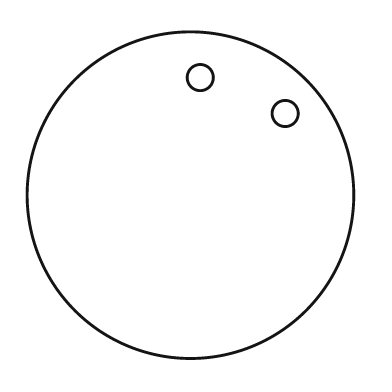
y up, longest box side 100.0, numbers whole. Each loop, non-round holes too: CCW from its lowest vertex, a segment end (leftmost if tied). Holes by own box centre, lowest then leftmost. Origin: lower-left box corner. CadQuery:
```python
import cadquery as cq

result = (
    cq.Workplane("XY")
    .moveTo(50.0, 50.0)
    .circle(50.0)
    .moveTo(79.0, 75.0)
    .circle(4.0)
    .moveTo(53.0, 86.0)
    .circle(4.0)
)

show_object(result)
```